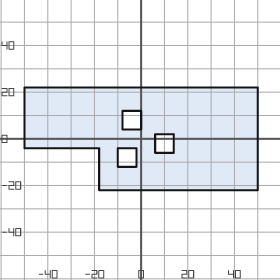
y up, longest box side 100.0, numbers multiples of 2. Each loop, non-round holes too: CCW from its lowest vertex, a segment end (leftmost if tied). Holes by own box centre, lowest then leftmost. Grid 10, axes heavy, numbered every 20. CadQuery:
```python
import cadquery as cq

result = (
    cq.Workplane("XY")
    .moveTo(-18.0, -22.0)
    .lineTo(50.0, -22.0)
    .lineTo(50.0, 22.0)
    .lineTo(-50.0, 22.0)
    .lineTo(-50.0, -4.0)
    .lineTo(-18.0, -4.0)
    .close()
    .moveTo(-10.0, -12.0)
    .lineTo(-2.0, -12.0)
    .lineTo(-2.0, -4.0)
    .lineTo(-10.0, -4.0)
    .close()
    .moveTo(6.0, -6.0)
    .lineTo(14.0, -6.0)
    .lineTo(14.0, 2.0)
    .lineTo(6.0, 2.0)
    .close()
    .moveTo(-8.0, 4.0)
    .lineTo(0.0, 4.0)
    .lineTo(0.0, 12.0)
    .lineTo(-8.0, 12.0)
    .close()
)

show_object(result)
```